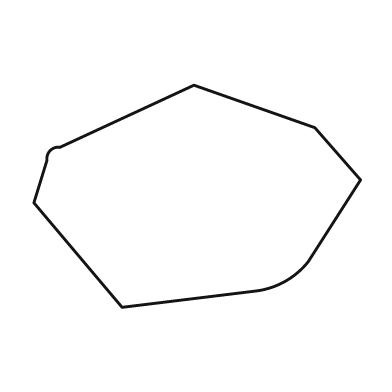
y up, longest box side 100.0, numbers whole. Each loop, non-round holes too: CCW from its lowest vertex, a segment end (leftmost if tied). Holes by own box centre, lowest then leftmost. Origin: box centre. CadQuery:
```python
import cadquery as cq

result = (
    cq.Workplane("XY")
    .moveTo(-23.0, -34.0)
    .lineTo(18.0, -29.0)
    .threePointArc((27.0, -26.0), (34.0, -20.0))
    .lineTo(50.0, 5.0)
    .lineTo(36.0, 21.0)
    .lineTo(-1.0, 34.0)
    .lineTo(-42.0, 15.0)
    .threePointArc((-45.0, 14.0), (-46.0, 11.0))
    .lineTo(-50.0, -2.0)
    .close()
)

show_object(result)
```